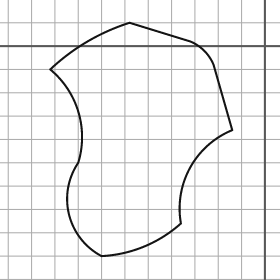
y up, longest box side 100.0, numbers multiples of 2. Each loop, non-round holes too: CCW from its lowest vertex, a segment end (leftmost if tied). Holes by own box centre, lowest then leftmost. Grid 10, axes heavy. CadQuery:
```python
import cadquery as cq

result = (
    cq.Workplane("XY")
    .moveTo(-70.0, -90.0)
    .threePointArc((-52.0, -86.0), (-36.0, -76.0))
    .threePointArc((-32.0, -52.0), (-14.0, -36.0))
    .lineTo(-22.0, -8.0)
    .threePointArc((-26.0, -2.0), (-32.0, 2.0))
    .lineTo(-58.0, 10.0)
    .threePointArc((-76.0, 2.0), (-92.0, -10.0))
    .threePointArc((-80.0, -28.0), (-80.0, -50.0))
    .threePointArc((-84.0, -72.0), (-70.0, -90.0))
    .close()
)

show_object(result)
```